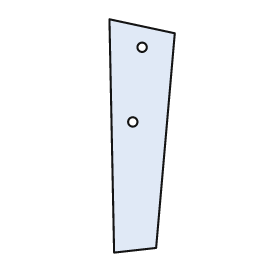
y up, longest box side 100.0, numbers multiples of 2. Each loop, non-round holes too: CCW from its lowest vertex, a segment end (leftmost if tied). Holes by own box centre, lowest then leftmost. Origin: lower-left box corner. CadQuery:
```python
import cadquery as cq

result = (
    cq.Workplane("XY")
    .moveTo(2.0, 0.0)
    .lineTo(20.0, 2.0)
    .lineTo(28.0, 94.0)
    .lineTo(0.0, 100.0)
    .close()
    .moveTo(10.0, 56.0)
    .circle(2.0)
    .moveTo(14.0, 88.0)
    .circle(2.0)
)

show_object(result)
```